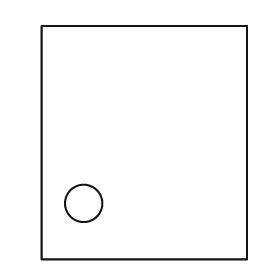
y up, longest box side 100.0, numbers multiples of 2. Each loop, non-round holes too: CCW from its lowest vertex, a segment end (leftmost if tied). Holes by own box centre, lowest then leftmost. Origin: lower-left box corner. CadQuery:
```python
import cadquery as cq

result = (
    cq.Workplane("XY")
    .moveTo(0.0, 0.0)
    .lineTo(88.0, 0.0)
    .lineTo(88.0, 100.0)
    .lineTo(0.0, 100.0)
    .close()
    .moveTo(18.0, 24.0)
    .circle(8.0)
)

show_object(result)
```